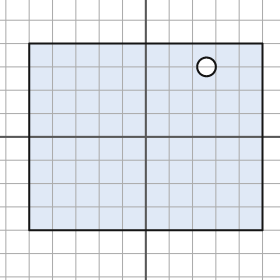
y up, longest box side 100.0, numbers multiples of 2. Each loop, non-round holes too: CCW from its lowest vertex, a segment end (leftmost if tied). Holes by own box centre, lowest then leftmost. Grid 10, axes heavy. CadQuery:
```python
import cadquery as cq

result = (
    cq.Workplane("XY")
    .moveTo(-50.0, -40.0)
    .lineTo(50.0, -40.0)
    .lineTo(50.0, 40.0)
    .lineTo(-50.0, 40.0)
    .close()
    .moveTo(26.0, 30.0)
    .circle(4.0)
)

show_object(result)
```